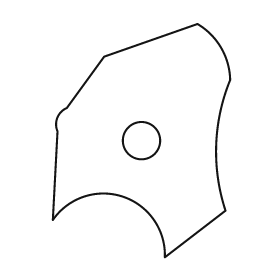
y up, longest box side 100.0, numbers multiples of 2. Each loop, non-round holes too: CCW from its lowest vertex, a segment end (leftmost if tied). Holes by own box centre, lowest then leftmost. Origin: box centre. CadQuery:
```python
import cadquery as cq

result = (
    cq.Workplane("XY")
    .moveTo(10.0, -50.0)
    .lineTo(36.0, -30.0)
    .threePointArc((32.0, -2.0), (38.0, 26.0))
    .threePointArc((34.0, 40.0), (24.0, 50.0))
    .lineTo(-16.0, 36.0)
    .lineTo(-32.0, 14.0)
    .threePointArc((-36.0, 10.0), (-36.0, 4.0))
    .lineTo(-38.0, -34.0)
    .threePointArc((-8.0, -24.0), (10.0, -50.0))
    .close()
    .moveTo(0.0, 0.0)
    .circle(8.0)
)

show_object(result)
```